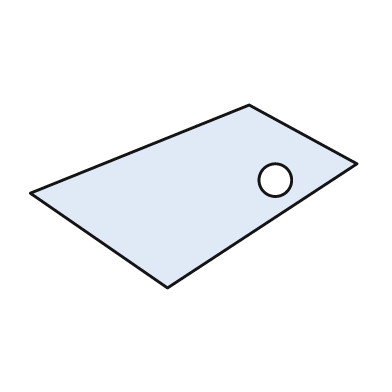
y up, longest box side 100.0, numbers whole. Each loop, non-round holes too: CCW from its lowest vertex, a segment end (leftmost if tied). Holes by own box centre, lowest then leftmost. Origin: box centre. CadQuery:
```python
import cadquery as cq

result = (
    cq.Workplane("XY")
    .moveTo(-8.0, -28.0)
    .lineTo(50.0, 10.0)
    .lineTo(17.0, 28.0)
    .lineTo(-50.0, 1.0)
    .close()
    .moveTo(25.0, 5.0)
    .circle(5.0)
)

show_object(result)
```